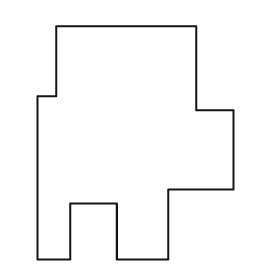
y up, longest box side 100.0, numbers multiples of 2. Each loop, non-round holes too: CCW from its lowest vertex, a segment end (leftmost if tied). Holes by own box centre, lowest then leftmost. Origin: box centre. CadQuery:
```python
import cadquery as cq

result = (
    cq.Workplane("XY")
    .moveTo(-42.0, -50.0)
    .lineTo(-28.0, -50.0)
    .lineTo(-28.0, -26.0)
    .lineTo(-8.0, -26.0)
    .lineTo(-8.0, -50.0)
    .lineTo(14.0, -50.0)
    .lineTo(14.0, -20.0)
    .lineTo(42.0, -20.0)
    .lineTo(42.0, 14.0)
    .lineTo(26.0, 14.0)
    .lineTo(26.0, 50.0)
    .lineTo(-34.0, 50.0)
    .lineTo(-34.0, 20.0)
    .lineTo(-42.0, 20.0)
    .close()
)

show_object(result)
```